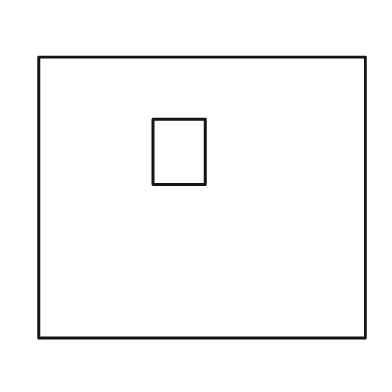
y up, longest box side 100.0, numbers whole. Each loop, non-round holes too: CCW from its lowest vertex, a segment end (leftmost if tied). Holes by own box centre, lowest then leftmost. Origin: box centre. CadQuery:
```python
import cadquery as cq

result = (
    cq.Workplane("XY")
    .moveTo(-50.0, -43.0)
    .lineTo(50.0, -43.0)
    .lineTo(50.0, 43.0)
    .lineTo(-50.0, 43.0)
    .close()
    .moveTo(-15.0, 4.0)
    .lineTo(1.0, 4.0)
    .lineTo(1.0, 24.0)
    .lineTo(-15.0, 24.0)
    .close()
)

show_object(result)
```